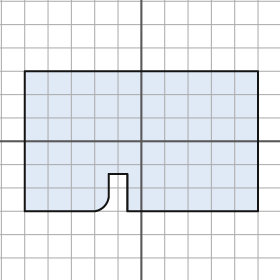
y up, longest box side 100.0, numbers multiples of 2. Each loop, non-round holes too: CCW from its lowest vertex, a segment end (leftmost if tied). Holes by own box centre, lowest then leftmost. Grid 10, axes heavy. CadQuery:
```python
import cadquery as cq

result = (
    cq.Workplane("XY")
    .moveTo(-50.0, -30.0)
    .lineTo(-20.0, -30.0)
    .threePointArc((-16.0, -28.0), (-14.0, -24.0))
    .lineTo(-14.0, -14.0)
    .lineTo(-6.0, -14.0)
    .lineTo(-6.0, -30.0)
    .lineTo(50.0, -30.0)
    .lineTo(50.0, 30.0)
    .lineTo(-50.0, 30.0)
    .close()
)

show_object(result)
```